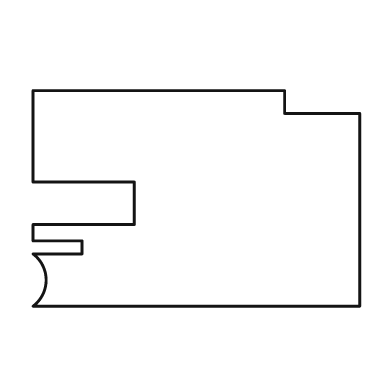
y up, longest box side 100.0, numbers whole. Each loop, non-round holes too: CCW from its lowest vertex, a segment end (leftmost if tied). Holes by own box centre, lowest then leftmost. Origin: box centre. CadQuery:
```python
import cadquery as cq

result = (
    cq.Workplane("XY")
    .moveTo(-50.0, -33.0)
    .lineTo(50.0, -33.0)
    .lineTo(50.0, 26.0)
    .lineTo(27.0, 26.0)
    .lineTo(27.0, 33.0)
    .lineTo(-50.0, 33.0)
    .lineTo(-50.0, 5.0)
    .lineTo(-19.0, 5.0)
    .lineTo(-19.0, -8.0)
    .lineTo(-50.0, -8.0)
    .lineTo(-50.0, -13.0)
    .lineTo(-35.0, -13.0)
    .lineTo(-35.0, -17.0)
    .lineTo(-50.0, -17.0)
    .threePointArc((-46.0, -25.0), (-50.0, -33.0))
    .close()
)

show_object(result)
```